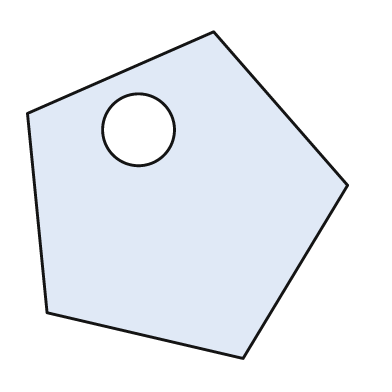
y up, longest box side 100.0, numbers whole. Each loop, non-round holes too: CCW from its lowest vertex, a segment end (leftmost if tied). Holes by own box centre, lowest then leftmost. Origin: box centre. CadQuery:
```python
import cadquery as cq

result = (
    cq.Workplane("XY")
    .moveTo(17.0, -50.0)
    .lineTo(49.0, 3.0)
    .lineTo(8.0, 50.0)
    .lineTo(-49.0, 25.0)
    .lineTo(-43.0, -36.0)
    .close()
    .moveTo(-15.0, 20.0)
    .circle(11.0)
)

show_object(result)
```